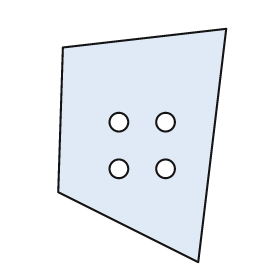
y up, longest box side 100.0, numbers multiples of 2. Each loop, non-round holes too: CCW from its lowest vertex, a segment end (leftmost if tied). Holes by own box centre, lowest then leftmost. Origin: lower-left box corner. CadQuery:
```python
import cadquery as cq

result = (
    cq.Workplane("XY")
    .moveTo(60.0, 0.0)
    .lineTo(72.0, 100.0)
    .lineTo(2.0, 92.0)
    .lineTo(0.0, 30.0)
    .close()
    .moveTo(26.0, 40.0)
    .circle(4.0)
    .moveTo(46.0, 40.0)
    .circle(4.0)
    .moveTo(26.0, 60.0)
    .circle(4.0)
    .moveTo(46.0, 60.0)
    .circle(4.0)
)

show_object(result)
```